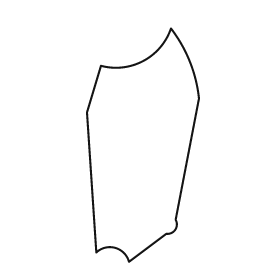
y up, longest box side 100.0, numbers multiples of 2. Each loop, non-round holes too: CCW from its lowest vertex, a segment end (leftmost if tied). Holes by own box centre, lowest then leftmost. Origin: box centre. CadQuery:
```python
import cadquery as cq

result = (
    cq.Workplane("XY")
    .moveTo(-6.0, -50.0)
    .lineTo(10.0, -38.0)
    .threePointArc((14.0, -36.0), (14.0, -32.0))
    .lineTo(24.0, 20.0)
    .threePointArc((20.0, 36.0), (12.0, 50.0))
    .threePointArc((0.0, 36.0), (-18.0, 34.0))
    .lineTo(-24.0, 14.0)
    .lineTo(-20.0, -46.0)
    .threePointArc((-12.0, -44.0), (-6.0, -50.0))
    .close()
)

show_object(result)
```